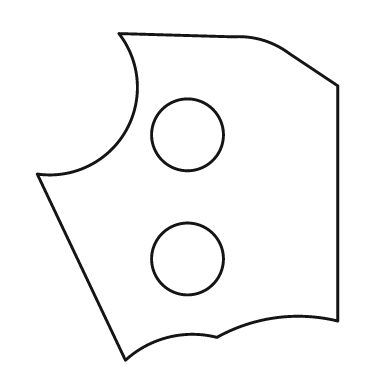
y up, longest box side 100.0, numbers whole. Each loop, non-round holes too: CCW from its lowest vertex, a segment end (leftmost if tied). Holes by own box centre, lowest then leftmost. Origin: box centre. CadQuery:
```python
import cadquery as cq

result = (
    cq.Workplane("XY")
    .moveTo(-19.0, -50.0)
    .threePointArc((-6.0, -43.0), (9.0, -43.0))
    .threePointArc((27.0, -37.0), (46.0, -38.0))
    .lineTo(46.0, 34.0)
    .lineTo(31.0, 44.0)
    .threePointArc((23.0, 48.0), (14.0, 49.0))
    .lineTo(-21.0, 50.0)
    .threePointArc((-19.0, 20.0), (-46.0, 7.0))
    .close()
    .moveTo(0.0, -19.0)
    .circle(11.0)
    .moveTo(0.0, 19.0)
    .circle(11.0)
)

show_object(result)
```